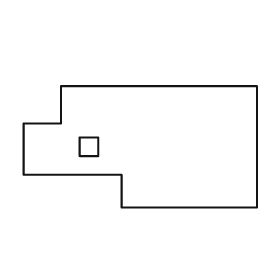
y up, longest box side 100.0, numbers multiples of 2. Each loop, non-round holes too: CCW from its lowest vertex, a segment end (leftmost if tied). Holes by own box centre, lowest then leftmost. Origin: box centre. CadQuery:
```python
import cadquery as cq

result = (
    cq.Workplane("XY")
    .moveTo(-8.0, -26.0)
    .lineTo(50.0, -26.0)
    .lineTo(50.0, 26.0)
    .lineTo(-34.0, 26.0)
    .lineTo(-34.0, 10.0)
    .lineTo(-50.0, 10.0)
    .lineTo(-50.0, -12.0)
    .lineTo(-8.0, -12.0)
    .close()
    .moveTo(-26.0, -4.0)
    .lineTo(-18.0, -4.0)
    .lineTo(-18.0, 4.0)
    .lineTo(-26.0, 4.0)
    .close()
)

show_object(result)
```